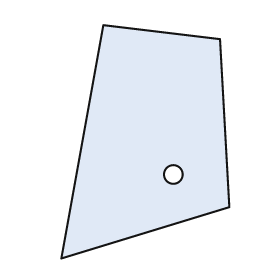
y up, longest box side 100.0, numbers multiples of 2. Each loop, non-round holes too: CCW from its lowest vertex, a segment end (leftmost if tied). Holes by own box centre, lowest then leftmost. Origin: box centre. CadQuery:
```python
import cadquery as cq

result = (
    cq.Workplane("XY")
    .moveTo(-36.0, -50.0)
    .lineTo(36.0, -28.0)
    .lineTo(32.0, 44.0)
    .lineTo(-18.0, 50.0)
    .close()
    .moveTo(12.0, -14.0)
    .circle(4.0)
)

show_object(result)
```